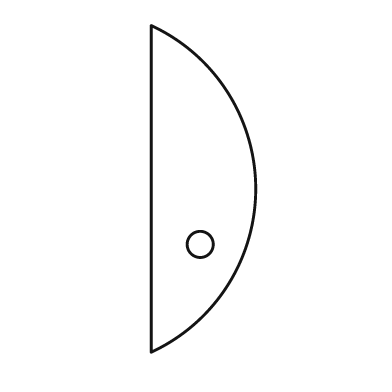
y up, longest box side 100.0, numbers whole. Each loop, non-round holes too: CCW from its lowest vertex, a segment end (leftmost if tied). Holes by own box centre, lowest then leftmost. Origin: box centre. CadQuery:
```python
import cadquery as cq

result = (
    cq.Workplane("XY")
    .moveTo(-16.0, -50.0)
    .threePointArc((16.0, 0.0), (-16.0, 50.0))
    .close()
    .moveTo(-1.0, -17.0)
    .circle(4.0)
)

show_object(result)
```